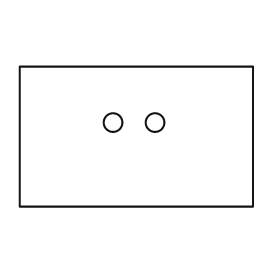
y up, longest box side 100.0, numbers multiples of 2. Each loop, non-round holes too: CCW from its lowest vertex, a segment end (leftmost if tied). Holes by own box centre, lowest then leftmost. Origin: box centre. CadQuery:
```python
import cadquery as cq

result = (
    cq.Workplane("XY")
    .moveTo(-50.0, -30.0)
    .lineTo(50.0, -30.0)
    .lineTo(50.0, 30.0)
    .lineTo(-50.0, 30.0)
    .close()
    .moveTo(-10.0, 6.0)
    .circle(4.0)
    .moveTo(8.0, 6.0)
    .circle(4.0)
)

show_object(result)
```